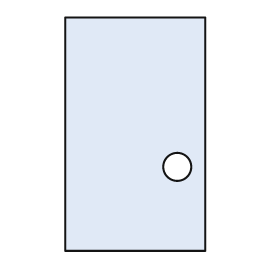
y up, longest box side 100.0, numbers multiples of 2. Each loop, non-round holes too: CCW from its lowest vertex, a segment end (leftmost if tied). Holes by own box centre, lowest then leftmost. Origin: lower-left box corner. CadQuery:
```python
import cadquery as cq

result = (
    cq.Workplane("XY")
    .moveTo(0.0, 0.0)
    .lineTo(60.0, 0.0)
    .lineTo(60.0, 100.0)
    .lineTo(0.0, 100.0)
    .close()
    .moveTo(48.0, 36.0)
    .circle(6.0)
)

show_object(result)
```